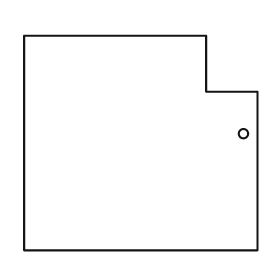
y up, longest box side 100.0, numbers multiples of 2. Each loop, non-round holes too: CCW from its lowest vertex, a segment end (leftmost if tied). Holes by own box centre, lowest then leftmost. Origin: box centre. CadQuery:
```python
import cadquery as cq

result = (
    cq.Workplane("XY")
    .moveTo(-50.0, -46.0)
    .lineTo(50.0, -46.0)
    .lineTo(50.0, 22.0)
    .lineTo(28.0, 22.0)
    .lineTo(28.0, 46.0)
    .lineTo(-50.0, 46.0)
    .close()
    .moveTo(44.0, 4.0)
    .circle(2.0)
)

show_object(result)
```